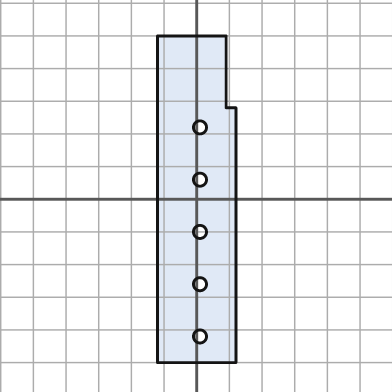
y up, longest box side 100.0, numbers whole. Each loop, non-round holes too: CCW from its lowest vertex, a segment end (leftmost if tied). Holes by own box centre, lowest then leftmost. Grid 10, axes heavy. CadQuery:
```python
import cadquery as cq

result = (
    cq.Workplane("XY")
    .moveTo(-12.0, -50.0)
    .lineTo(12.0, -50.0)
    .lineTo(12.0, 28.0)
    .lineTo(9.0, 28.0)
    .lineTo(9.0, 50.0)
    .lineTo(-12.0, 50.0)
    .close()
    .moveTo(1.0, -42.0)
    .circle(2.0)
    .moveTo(1.0, -26.0)
    .circle(2.0)
    .moveTo(1.0, -10.0)
    .circle(2.0)
    .moveTo(1.0, 6.0)
    .circle(2.0)
    .moveTo(1.0, 22.0)
    .circle(2.0)
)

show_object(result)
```